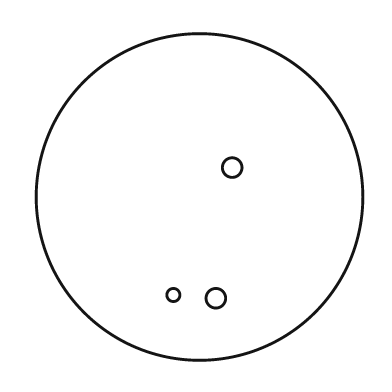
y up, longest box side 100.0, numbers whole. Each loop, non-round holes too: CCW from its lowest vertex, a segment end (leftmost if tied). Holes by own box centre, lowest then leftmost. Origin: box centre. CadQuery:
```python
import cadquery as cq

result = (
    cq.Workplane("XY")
    .moveTo(0.0, 0.0)
    .circle(50.0)
    .moveTo(5.0, -31.0)
    .circle(3.0)
    .moveTo(-8.0, -30.0)
    .circle(2.0)
    .moveTo(10.0, 9.0)
    .circle(3.0)
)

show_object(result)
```